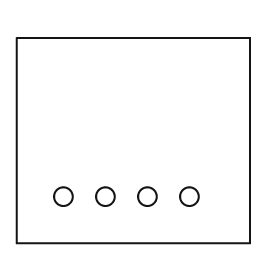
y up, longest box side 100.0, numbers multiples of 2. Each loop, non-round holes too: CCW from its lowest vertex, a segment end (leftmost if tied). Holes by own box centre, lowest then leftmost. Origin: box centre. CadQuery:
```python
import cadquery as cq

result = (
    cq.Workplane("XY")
    .moveTo(-50.0, -44.0)
    .lineTo(50.0, -44.0)
    .lineTo(50.0, 44.0)
    .lineTo(-50.0, 44.0)
    .close()
    .moveTo(-30.0, -24.0)
    .circle(4.0)
    .moveTo(-12.0, -24.0)
    .circle(4.0)
    .moveTo(6.0, -24.0)
    .circle(4.0)
    .moveTo(24.0, -24.0)
    .circle(4.0)
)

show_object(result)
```